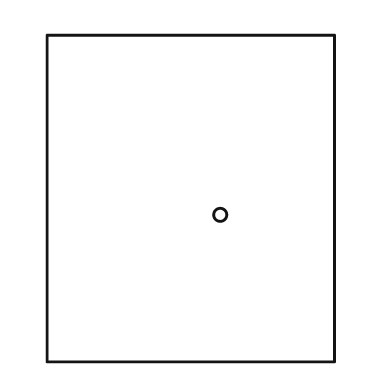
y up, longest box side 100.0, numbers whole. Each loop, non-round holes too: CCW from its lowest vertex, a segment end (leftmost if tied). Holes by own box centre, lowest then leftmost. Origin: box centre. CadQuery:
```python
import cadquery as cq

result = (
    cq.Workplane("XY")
    .moveTo(-44.0, -50.0)
    .lineTo(44.0, -50.0)
    .lineTo(44.0, 50.0)
    .lineTo(-44.0, 50.0)
    .close()
    .moveTo(9.0, -5.0)
    .circle(2.0)
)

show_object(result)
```